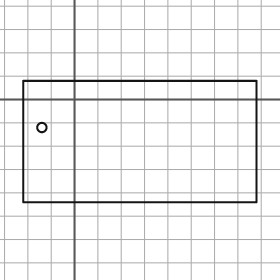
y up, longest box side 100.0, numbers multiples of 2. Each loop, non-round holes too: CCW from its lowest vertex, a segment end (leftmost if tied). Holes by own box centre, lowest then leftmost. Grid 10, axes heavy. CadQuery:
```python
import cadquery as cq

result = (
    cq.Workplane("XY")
    .moveTo(-22.0, -44.0)
    .lineTo(78.0, -44.0)
    .lineTo(78.0, 8.0)
    .lineTo(-22.0, 8.0)
    .close()
    .moveTo(-14.0, -12.0)
    .circle(2.0)
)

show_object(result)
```